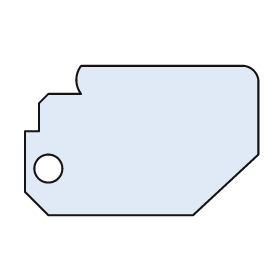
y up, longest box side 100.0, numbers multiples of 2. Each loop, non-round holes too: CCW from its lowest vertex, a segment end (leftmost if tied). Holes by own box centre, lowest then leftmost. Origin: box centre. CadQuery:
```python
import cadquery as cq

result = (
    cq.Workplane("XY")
    .moveTo(-40.0, -32.0)
    .lineTo(22.0, -32.0)
    .lineTo(50.0, -6.0)
    .lineTo(50.0, 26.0)
    .threePointArc((48.0, 30.0), (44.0, 32.0))
    .lineTo(-26.0, 32.0)
    .threePointArc((-28.0, 26.0), (-26.0, 20.0))
    .lineTo(-40.0, 20.0)
    .lineTo(-44.0, 16.0)
    .lineTo(-44.0, 4.0)
    .lineTo(-50.0, 4.0)
    .lineTo(-50.0, -22.0)
    .close()
    .moveTo(-40.0, -12.0)
    .circle(6.0)
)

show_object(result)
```